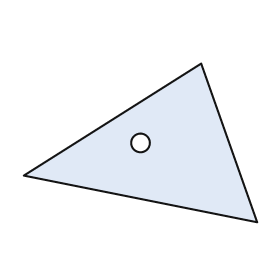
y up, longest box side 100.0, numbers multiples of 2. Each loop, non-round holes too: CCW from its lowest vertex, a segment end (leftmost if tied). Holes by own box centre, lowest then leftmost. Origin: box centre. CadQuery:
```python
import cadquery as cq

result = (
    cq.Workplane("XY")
    .moveTo(50.0, -34.0)
    .lineTo(26.0, 34.0)
    .lineTo(-50.0, -14.0)
    .close()
    .moveTo(0.0, 0.0)
    .circle(4.0)
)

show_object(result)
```